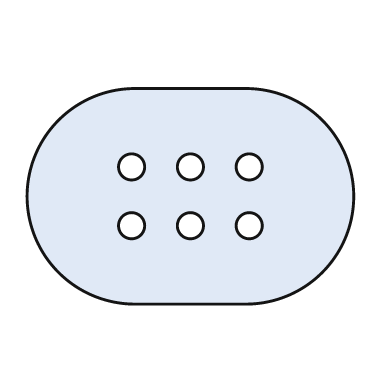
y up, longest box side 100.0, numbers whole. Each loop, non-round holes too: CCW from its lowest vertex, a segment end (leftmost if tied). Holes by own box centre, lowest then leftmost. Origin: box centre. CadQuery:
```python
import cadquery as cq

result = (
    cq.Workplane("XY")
    .moveTo(-17.0, -33.0)
    .lineTo(17.0, -33.0)
    .threePointArc((50.0, 0.0), (17.0, 33.0))
    .lineTo(-17.0, 33.0)
    .threePointArc((-50.0, 0.0), (-17.0, -33.0))
    .close()
    .moveTo(-18.0, -9.0)
    .circle(4.0)
    .moveTo(0.0, -9.0)
    .circle(4.0)
    .moveTo(18.0, -9.0)
    .circle(4.0)
    .moveTo(-18.0, 9.0)
    .circle(4.0)
    .moveTo(0.0, 9.0)
    .circle(4.0)
    .moveTo(18.0, 9.0)
    .circle(4.0)
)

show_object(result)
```